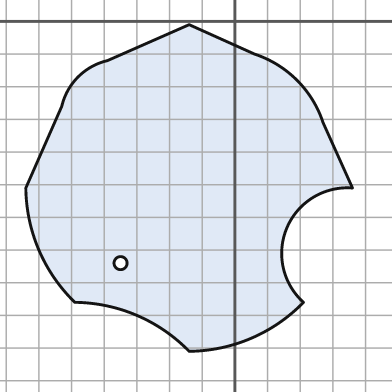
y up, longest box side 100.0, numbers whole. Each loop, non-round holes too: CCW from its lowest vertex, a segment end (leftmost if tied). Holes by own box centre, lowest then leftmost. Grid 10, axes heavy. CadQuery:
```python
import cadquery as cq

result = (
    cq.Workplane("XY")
    .moveTo(-14.0, -101.0)
    .threePointArc((5.0, -97.0), (21.0, -86.0))
    .threePointArc((16.0, -63.0), (36.0, -51.0))
    .lineTo(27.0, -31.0)
    .threePointArc((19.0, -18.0), (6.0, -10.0))
    .lineTo(-14.0, -1.0)
    .lineTo(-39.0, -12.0)
    .threePointArc((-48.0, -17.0), (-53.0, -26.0))
    .lineTo(-64.0, -51.0)
    .threePointArc((-60.0, -70.0), (-49.0, -86.0))
    .threePointArc((-30.0, -90.0), (-14.0, -101.0))
    .close()
    .moveTo(-35.0, -74.0)
    .circle(2.0)
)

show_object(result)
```